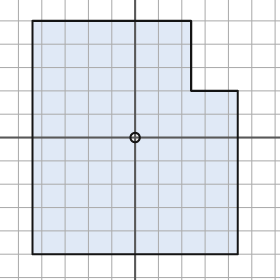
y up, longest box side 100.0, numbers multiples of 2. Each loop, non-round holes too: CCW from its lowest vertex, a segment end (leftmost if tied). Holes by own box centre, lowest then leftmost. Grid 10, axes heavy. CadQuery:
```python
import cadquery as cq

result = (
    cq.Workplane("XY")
    .moveTo(-44.0, -50.0)
    .lineTo(44.0, -50.0)
    .lineTo(44.0, 20.0)
    .lineTo(24.0, 20.0)
    .lineTo(24.0, 50.0)
    .lineTo(-44.0, 50.0)
    .close()
    .moveTo(0.0, 0.0)
    .circle(2.0)
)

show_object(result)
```